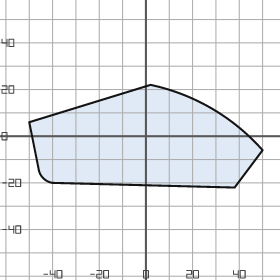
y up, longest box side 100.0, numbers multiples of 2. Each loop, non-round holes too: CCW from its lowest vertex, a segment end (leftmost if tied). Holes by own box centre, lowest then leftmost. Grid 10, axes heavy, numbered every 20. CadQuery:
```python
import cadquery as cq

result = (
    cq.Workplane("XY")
    .moveTo(38.0, -22.0)
    .lineTo(50.0, -6.0)
    .threePointArc((28.0, 12.0), (2.0, 22.0))
    .lineTo(-50.0, 6.0)
    .lineTo(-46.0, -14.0)
    .threePointArc((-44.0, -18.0), (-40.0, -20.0))
    .close()
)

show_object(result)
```